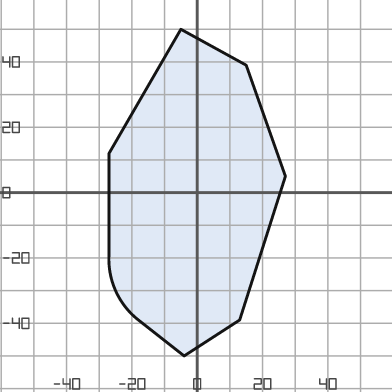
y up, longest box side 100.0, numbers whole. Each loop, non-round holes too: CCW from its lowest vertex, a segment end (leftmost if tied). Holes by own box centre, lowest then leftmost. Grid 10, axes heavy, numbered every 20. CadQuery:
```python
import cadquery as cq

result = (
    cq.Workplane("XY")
    .moveTo(-4.0, -50.0)
    .lineTo(13.0, -39.0)
    .lineTo(27.0, 5.0)
    .lineTo(15.0, 39.0)
    .lineTo(-5.0, 50.0)
    .lineTo(-27.0, 12.0)
    .lineTo(-27.0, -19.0)
    .threePointArc((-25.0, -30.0), (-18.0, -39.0))
    .close()
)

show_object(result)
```